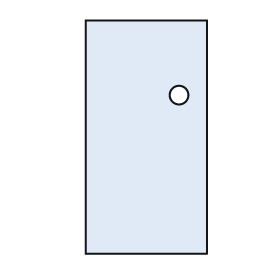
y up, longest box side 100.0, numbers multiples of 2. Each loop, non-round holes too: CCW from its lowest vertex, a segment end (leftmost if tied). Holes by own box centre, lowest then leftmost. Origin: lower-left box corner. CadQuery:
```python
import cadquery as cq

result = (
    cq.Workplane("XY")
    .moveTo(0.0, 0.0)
    .lineTo(52.0, 0.0)
    .lineTo(52.0, 100.0)
    .lineTo(0.0, 100.0)
    .close()
    .moveTo(40.0, 68.0)
    .circle(4.0)
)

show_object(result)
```